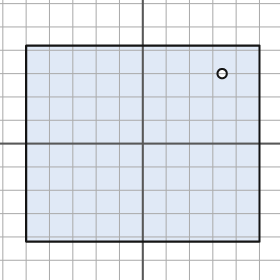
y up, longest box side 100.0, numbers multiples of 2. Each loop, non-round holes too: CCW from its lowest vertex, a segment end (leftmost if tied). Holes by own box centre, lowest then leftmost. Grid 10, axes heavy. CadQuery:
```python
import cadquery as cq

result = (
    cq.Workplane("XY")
    .moveTo(-50.0, -42.0)
    .lineTo(50.0, -42.0)
    .lineTo(50.0, 42.0)
    .lineTo(-50.0, 42.0)
    .close()
    .moveTo(34.0, 30.0)
    .circle(2.0)
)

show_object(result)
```